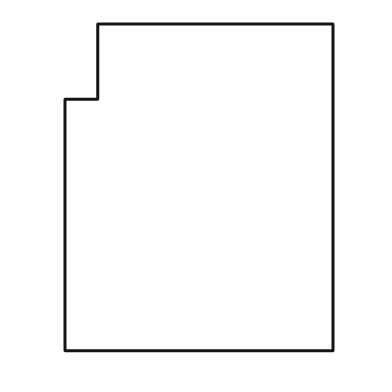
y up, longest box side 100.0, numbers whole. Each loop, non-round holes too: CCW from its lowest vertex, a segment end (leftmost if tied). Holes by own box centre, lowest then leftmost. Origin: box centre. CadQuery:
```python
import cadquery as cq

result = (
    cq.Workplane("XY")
    .moveTo(-41.0, -50.0)
    .lineTo(41.0, -50.0)
    .lineTo(41.0, 50.0)
    .lineTo(-31.0, 50.0)
    .lineTo(-31.0, 27.0)
    .lineTo(-41.0, 27.0)
    .close()
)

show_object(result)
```